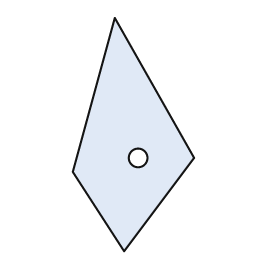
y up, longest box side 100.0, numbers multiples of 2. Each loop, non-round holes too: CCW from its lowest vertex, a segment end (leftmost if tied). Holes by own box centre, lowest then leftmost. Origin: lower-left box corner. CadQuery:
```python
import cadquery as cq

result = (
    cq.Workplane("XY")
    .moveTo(22.0, 0.0)
    .lineTo(52.0, 40.0)
    .lineTo(18.0, 100.0)
    .lineTo(0.0, 34.0)
    .close()
    .moveTo(28.0, 40.0)
    .circle(4.0)
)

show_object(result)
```